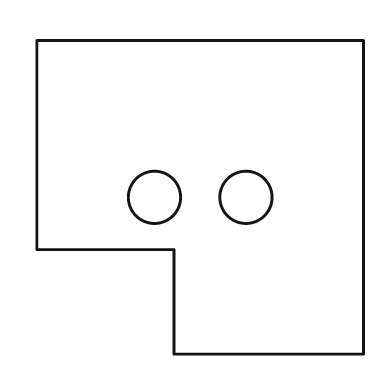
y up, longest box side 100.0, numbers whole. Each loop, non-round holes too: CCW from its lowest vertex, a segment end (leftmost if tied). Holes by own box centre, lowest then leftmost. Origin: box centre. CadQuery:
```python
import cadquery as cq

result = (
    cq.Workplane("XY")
    .moveTo(-8.0, -48.0)
    .lineTo(50.0, -48.0)
    .lineTo(50.0, 48.0)
    .lineTo(-50.0, 48.0)
    .lineTo(-50.0, -16.0)
    .lineTo(-8.0, -16.0)
    .close()
    .moveTo(-14.0, 0.0)
    .circle(8.0)
    .moveTo(14.0, 0.0)
    .circle(8.0)
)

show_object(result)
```